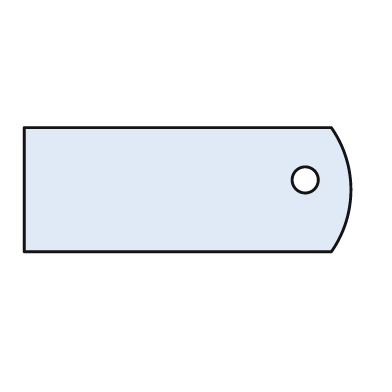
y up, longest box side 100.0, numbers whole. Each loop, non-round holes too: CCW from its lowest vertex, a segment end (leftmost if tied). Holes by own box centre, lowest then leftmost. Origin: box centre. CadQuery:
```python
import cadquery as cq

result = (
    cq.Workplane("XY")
    .moveTo(-50.0, -19.0)
    .lineTo(44.0, -19.0)
    .threePointArc((50.0, 0.0), (44.0, 19.0))
    .lineTo(-50.0, 19.0)
    .close()
    .moveTo(36.0, 3.0)
    .circle(4.0)
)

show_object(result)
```